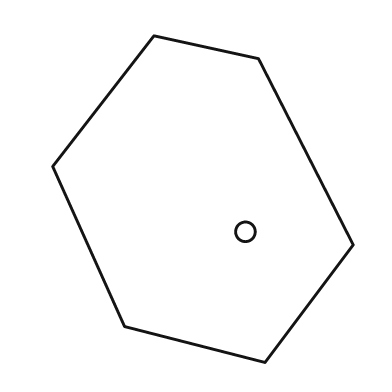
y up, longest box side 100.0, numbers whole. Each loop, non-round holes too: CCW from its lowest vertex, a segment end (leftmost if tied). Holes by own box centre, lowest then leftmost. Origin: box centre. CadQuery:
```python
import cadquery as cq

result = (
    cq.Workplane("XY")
    .moveTo(19.0, -50.0)
    .lineTo(46.0, -14.0)
    .lineTo(17.0, 43.0)
    .lineTo(-15.0, 50.0)
    .lineTo(-46.0, 10.0)
    .lineTo(-24.0, -39.0)
    .close()
    .moveTo(13.0, -10.0)
    .circle(3.0)
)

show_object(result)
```